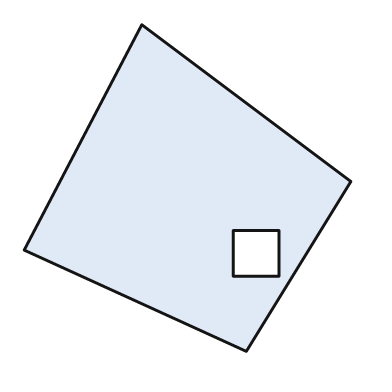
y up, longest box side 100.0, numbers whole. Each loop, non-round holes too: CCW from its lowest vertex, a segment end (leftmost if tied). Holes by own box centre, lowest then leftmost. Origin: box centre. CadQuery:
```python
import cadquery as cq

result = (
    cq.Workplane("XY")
    .moveTo(18.0, -50.0)
    .lineTo(50.0, 2.0)
    .lineTo(-14.0, 50.0)
    .lineTo(-50.0, -19.0)
    .close()
    .moveTo(14.0, -27.0)
    .lineTo(28.0, -27.0)
    .lineTo(28.0, -13.0)
    .lineTo(14.0, -13.0)
    .close()
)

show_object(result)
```